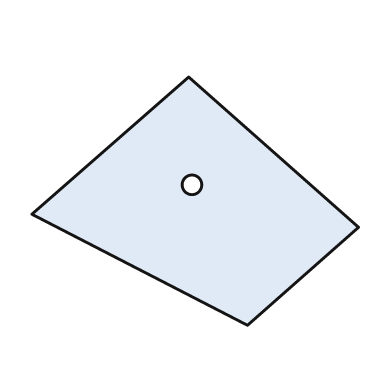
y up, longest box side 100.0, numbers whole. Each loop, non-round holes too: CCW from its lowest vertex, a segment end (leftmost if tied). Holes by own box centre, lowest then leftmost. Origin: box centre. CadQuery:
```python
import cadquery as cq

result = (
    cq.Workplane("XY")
    .moveTo(16.0, -38.0)
    .lineTo(50.0, -8.0)
    .lineTo(-2.0, 38.0)
    .lineTo(-50.0, -4.0)
    .close()
    .moveTo(-1.0, 5.0)
    .circle(3.0)
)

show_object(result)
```